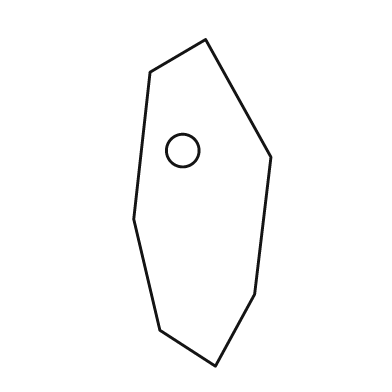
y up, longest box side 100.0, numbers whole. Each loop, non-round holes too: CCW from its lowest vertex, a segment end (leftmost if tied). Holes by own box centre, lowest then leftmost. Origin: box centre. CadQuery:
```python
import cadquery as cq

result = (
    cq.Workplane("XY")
    .moveTo(4.0, -50.0)
    .lineTo(16.0, -28.0)
    .lineTo(21.0, 14.0)
    .lineTo(1.0, 50.0)
    .lineTo(-16.0, 40.0)
    .lineTo(-21.0, -5.0)
    .lineTo(-13.0, -39.0)
    .close()
    .moveTo(-6.0, 16.0)
    .circle(5.0)
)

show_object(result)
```